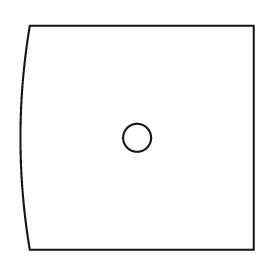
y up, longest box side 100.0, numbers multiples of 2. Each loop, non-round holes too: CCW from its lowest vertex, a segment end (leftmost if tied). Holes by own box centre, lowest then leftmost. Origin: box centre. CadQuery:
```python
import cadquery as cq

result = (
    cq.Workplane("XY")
    .moveTo(-46.0, -48.0)
    .lineTo(50.0, -48.0)
    .lineTo(50.0, 48.0)
    .lineTo(-46.0, 48.0)
    .threePointArc((-50.0, 0.0), (-46.0, -48.0))
    .close()
    .moveTo(0.0, 0.0)
    .circle(6.0)
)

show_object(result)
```